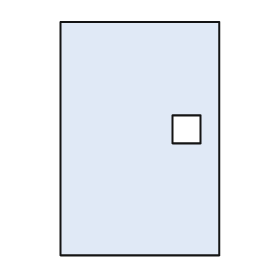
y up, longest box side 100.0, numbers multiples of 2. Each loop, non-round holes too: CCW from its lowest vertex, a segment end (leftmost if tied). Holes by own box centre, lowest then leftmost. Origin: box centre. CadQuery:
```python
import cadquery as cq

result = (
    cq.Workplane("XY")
    .moveTo(-34.0, -50.0)
    .lineTo(34.0, -50.0)
    .lineTo(34.0, 50.0)
    .lineTo(-34.0, 50.0)
    .close()
    .moveTo(14.0, -2.0)
    .lineTo(26.0, -2.0)
    .lineTo(26.0, 10.0)
    .lineTo(14.0, 10.0)
    .close()
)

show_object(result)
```